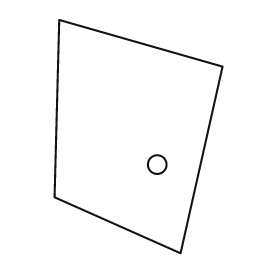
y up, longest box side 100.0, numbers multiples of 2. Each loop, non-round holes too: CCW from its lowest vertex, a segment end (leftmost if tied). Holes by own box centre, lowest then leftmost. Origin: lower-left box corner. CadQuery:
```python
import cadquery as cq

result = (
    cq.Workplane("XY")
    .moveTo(54.0, 0.0)
    .lineTo(72.0, 80.0)
    .lineTo(2.0, 100.0)
    .lineTo(0.0, 24.0)
    .close()
    .moveTo(44.0, 38.0)
    .circle(4.0)
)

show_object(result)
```